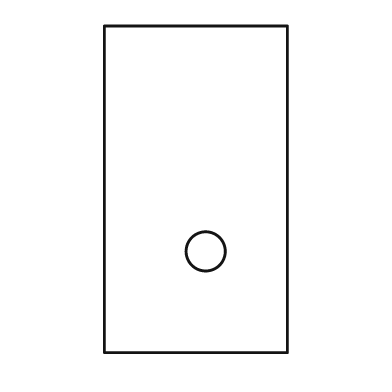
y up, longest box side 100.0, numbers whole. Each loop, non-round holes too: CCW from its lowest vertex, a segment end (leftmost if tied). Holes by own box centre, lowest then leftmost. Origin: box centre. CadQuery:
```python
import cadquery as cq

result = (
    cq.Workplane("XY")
    .moveTo(-28.0, -50.0)
    .lineTo(28.0, -50.0)
    .lineTo(28.0, 50.0)
    .lineTo(-28.0, 50.0)
    .close()
    .moveTo(3.0, -19.0)
    .circle(6.0)
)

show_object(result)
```